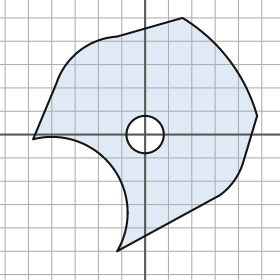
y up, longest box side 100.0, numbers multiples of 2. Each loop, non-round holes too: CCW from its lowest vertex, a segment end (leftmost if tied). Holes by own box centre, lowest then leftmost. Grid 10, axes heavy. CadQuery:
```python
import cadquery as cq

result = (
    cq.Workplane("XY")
    .moveTo(-12.0, -50.0)
    .lineTo(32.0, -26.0)
    .threePointArc((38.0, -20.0), (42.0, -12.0))
    .lineTo(48.0, 8.0)
    .threePointArc((36.0, 32.0), (16.0, 50.0))
    .lineTo(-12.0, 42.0)
    .threePointArc((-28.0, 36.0), (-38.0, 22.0))
    .lineTo(-48.0, -2.0)
    .threePointArc((-14.0, -14.0), (-12.0, -50.0))
    .close()
    .moveTo(0.0, 0.0)
    .circle(8.0)
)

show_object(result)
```